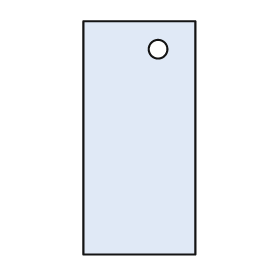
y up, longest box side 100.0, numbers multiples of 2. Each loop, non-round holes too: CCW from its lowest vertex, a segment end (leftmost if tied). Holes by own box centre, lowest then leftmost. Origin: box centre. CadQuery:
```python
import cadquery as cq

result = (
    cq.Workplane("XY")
    .moveTo(-24.0, -50.0)
    .lineTo(24.0, -50.0)
    .lineTo(24.0, 50.0)
    .lineTo(-24.0, 50.0)
    .close()
    .moveTo(8.0, 38.0)
    .circle(4.0)
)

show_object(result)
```